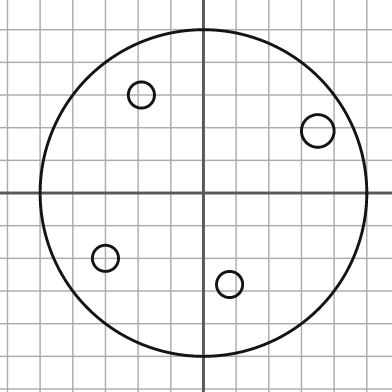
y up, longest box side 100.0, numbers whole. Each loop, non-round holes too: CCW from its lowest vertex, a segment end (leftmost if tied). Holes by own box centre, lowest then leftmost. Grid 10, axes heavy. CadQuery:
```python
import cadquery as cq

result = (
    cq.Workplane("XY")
    .moveTo(0.0, 0.0)
    .circle(50.0)
    .moveTo(8.0, -28.0)
    .circle(4.0)
    .moveTo(-30.0, -20.0)
    .circle(4.0)
    .moveTo(35.0, 19.0)
    .circle(5.0)
    .moveTo(-19.0, 30.0)
    .circle(4.0)
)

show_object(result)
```